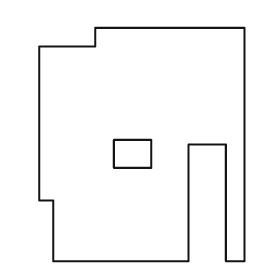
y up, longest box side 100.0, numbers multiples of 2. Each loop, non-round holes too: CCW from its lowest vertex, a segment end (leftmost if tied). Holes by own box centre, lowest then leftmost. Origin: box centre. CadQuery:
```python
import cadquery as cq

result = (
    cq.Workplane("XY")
    .moveTo(-38.0, -50.0)
    .lineTo(20.0, -50.0)
    .lineTo(20.0, 0.0)
    .lineTo(36.0, 0.0)
    .lineTo(36.0, -50.0)
    .lineTo(44.0, -50.0)
    .lineTo(44.0, 50.0)
    .lineTo(-20.0, 50.0)
    .lineTo(-20.0, 42.0)
    .lineTo(-44.0, 42.0)
    .lineTo(-44.0, -24.0)
    .lineTo(-38.0, -24.0)
    .close()
    .moveTo(-12.0, -10.0)
    .lineTo(4.0, -10.0)
    .lineTo(4.0, 2.0)
    .lineTo(-12.0, 2.0)
    .close()
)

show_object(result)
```